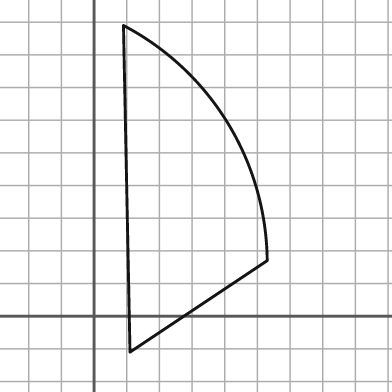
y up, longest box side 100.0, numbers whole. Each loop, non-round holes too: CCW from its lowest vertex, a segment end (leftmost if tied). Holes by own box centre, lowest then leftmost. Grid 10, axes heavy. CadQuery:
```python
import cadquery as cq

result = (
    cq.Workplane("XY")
    .moveTo(11.0, -11.0)
    .lineTo(53.0, 17.0)
    .threePointArc((41.0, 59.0), (9.0, 89.0))
    .close()
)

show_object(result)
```